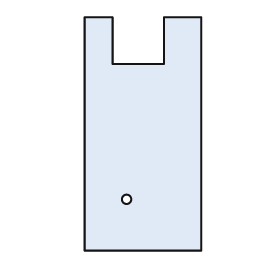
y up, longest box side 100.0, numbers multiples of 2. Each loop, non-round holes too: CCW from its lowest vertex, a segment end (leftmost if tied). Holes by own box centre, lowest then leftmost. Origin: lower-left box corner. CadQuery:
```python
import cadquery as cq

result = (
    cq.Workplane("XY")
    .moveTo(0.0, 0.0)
    .lineTo(50.0, 0.0)
    .lineTo(50.0, 100.0)
    .lineTo(34.0, 100.0)
    .lineTo(34.0, 80.0)
    .lineTo(12.0, 80.0)
    .lineTo(12.0, 100.0)
    .lineTo(0.0, 100.0)
    .close()
    .moveTo(18.0, 22.0)
    .circle(2.0)
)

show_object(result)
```